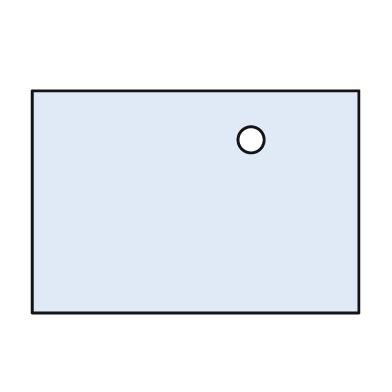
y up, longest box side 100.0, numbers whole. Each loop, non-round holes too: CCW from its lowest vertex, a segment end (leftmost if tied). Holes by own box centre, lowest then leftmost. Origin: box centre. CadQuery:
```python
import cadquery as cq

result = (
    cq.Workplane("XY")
    .moveTo(-50.0, -34.0)
    .lineTo(50.0, -34.0)
    .lineTo(50.0, 34.0)
    .lineTo(-50.0, 34.0)
    .close()
    .moveTo(17.0, 19.0)
    .circle(4.0)
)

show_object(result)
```